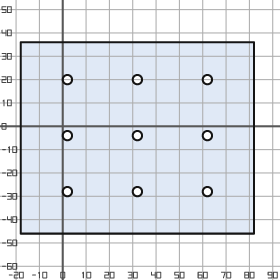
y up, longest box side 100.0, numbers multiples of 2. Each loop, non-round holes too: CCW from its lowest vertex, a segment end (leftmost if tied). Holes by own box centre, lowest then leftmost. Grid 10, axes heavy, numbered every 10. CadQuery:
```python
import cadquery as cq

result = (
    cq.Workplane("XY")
    .moveTo(-18.0, -46.0)
    .lineTo(82.0, -46.0)
    .lineTo(82.0, 36.0)
    .lineTo(-18.0, 36.0)
    .close()
    .moveTo(2.0, -28.0)
    .circle(2.0)
    .moveTo(32.0, -28.0)
    .circle(2.0)
    .moveTo(62.0, -28.0)
    .circle(2.0)
    .moveTo(2.0, -4.0)
    .circle(2.0)
    .moveTo(32.0, -4.0)
    .circle(2.0)
    .moveTo(62.0, -4.0)
    .circle(2.0)
    .moveTo(2.0, 20.0)
    .circle(2.0)
    .moveTo(32.0, 20.0)
    .circle(2.0)
    .moveTo(62.0, 20.0)
    .circle(2.0)
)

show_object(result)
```